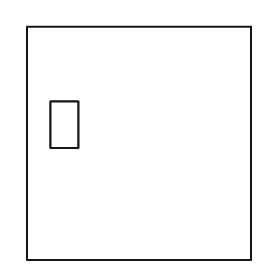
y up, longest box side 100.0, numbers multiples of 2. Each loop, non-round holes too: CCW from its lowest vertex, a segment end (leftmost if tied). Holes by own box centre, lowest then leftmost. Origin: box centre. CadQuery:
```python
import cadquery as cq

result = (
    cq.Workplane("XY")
    .moveTo(-48.0, -50.0)
    .lineTo(48.0, -50.0)
    .lineTo(48.0, 50.0)
    .lineTo(-48.0, 50.0)
    .close()
    .moveTo(-38.0, -2.0)
    .lineTo(-26.0, -2.0)
    .lineTo(-26.0, 18.0)
    .lineTo(-38.0, 18.0)
    .close()
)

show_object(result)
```